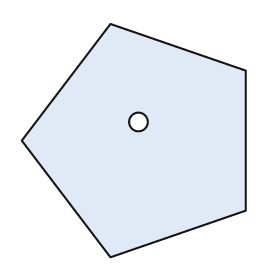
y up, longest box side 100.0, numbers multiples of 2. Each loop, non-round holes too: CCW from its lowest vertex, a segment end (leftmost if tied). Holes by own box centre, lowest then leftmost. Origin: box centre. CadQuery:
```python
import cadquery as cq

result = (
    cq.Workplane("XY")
    .moveTo(-10.0, -50.0)
    .lineTo(48.0, -30.0)
    .lineTo(48.0, 30.0)
    .lineTo(-10.0, 50.0)
    .lineTo(-48.0, 0.0)
    .close()
    .moveTo(2.0, 8.0)
    .circle(4.0)
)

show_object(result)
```